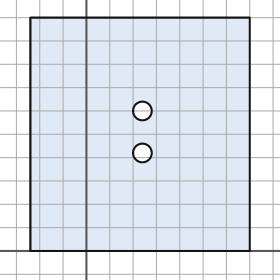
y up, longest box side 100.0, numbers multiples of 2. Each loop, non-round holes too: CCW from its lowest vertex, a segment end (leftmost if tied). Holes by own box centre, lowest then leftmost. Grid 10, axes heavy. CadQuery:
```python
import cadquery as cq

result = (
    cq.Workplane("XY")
    .moveTo(-24.0, 0.0)
    .lineTo(70.0, 0.0)
    .lineTo(70.0, 100.0)
    .lineTo(-24.0, 100.0)
    .close()
    .moveTo(24.0, 42.0)
    .circle(4.0)
    .moveTo(24.0, 60.0)
    .circle(4.0)
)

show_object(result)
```